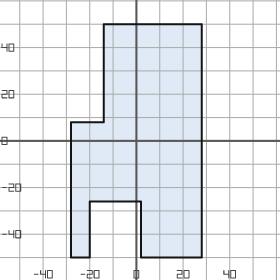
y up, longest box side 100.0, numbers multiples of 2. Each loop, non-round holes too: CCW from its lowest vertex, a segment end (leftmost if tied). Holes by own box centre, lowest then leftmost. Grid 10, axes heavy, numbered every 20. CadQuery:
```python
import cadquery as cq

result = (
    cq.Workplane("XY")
    .moveTo(-28.0, -50.0)
    .lineTo(-20.0, -50.0)
    .lineTo(-20.0, -26.0)
    .lineTo(2.0, -26.0)
    .lineTo(2.0, -50.0)
    .lineTo(28.0, -50.0)
    .lineTo(28.0, 50.0)
    .lineTo(-14.0, 50.0)
    .lineTo(-14.0, 8.0)
    .lineTo(-28.0, 8.0)
    .close()
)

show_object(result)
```